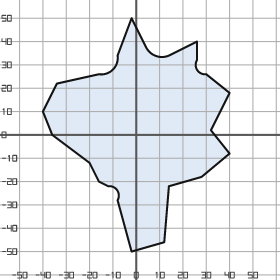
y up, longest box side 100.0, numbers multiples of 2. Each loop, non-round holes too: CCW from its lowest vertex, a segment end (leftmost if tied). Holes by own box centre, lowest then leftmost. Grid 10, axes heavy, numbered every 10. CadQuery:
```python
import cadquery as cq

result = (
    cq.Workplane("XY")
    .moveTo(-2.0, -50.0)
    .lineTo(12.0, -46.0)
    .lineTo(14.0, -22.0)
    .lineTo(28.0, -18.0)
    .lineTo(40.0, -8.0)
    .lineTo(32.0, 2.0)
    .lineTo(40.0, 18.0)
    .lineTo(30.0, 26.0)
    .threePointArc((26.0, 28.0), (26.0, 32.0))
    .lineTo(26.0, 40.0)
    .lineTo(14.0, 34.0)
    .threePointArc((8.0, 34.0), (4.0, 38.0))
    .lineTo(-2.0, 50.0)
    .lineTo(-8.0, 34.0)
    .threePointArc((-10.0, 28.0), (-16.0, 26.0))
    .lineTo(-34.0, 22.0)
    .lineTo(-40.0, 10.0)
    .lineTo(-36.0, 0.0)
    .lineTo(-20.0, -12.0)
    .lineTo(-16.0, -20.0)
    .lineTo(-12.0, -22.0)
    .threePointArc((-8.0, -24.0), (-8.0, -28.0))
    .close()
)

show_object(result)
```